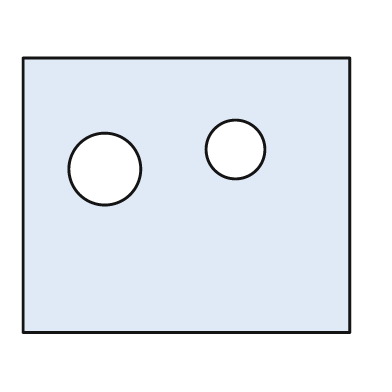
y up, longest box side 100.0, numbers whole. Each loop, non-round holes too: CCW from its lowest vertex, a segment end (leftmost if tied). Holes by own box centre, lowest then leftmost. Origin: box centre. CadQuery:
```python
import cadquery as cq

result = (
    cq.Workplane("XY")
    .moveTo(-50.0, -42.0)
    .lineTo(50.0, -42.0)
    .lineTo(50.0, 42.0)
    .lineTo(-50.0, 42.0)
    .close()
    .moveTo(-25.0, 8.0)
    .circle(11.0)
    .moveTo(15.0, 14.0)
    .circle(9.0)
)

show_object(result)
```